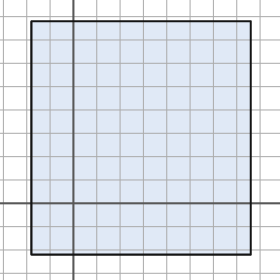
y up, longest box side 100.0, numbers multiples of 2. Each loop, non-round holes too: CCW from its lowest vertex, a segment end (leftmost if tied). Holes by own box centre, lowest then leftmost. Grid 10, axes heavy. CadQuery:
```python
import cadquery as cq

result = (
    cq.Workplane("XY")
    .moveTo(-18.0, -22.0)
    .lineTo(76.0, -22.0)
    .lineTo(76.0, 78.0)
    .lineTo(-18.0, 78.0)
    .close()
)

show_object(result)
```